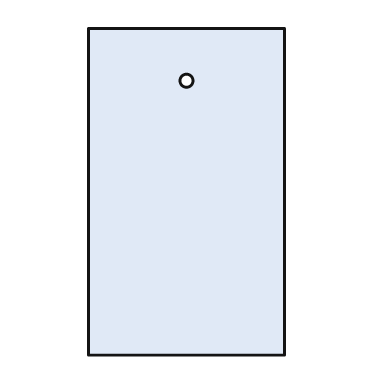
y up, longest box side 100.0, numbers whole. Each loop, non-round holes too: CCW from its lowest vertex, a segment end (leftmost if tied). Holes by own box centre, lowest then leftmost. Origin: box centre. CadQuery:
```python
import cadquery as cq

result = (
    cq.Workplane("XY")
    .moveTo(-30.0, -50.0)
    .lineTo(30.0, -50.0)
    .lineTo(30.0, 50.0)
    .lineTo(-30.0, 50.0)
    .close()
    .moveTo(0.0, 34.0)
    .circle(2.0)
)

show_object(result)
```